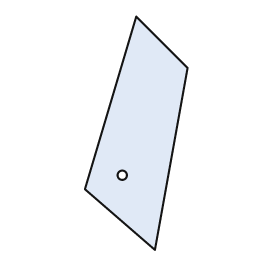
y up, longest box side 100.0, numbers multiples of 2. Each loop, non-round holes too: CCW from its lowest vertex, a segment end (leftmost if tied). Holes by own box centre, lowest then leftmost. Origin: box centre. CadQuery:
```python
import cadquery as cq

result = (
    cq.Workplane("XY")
    .moveTo(8.0, -50.0)
    .lineTo(22.0, 28.0)
    .lineTo(0.0, 50.0)
    .lineTo(-22.0, -24.0)
    .close()
    .moveTo(-6.0, -18.0)
    .circle(2.0)
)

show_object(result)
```